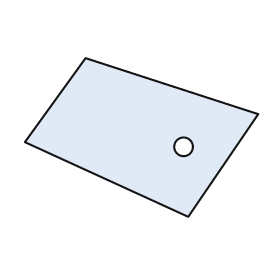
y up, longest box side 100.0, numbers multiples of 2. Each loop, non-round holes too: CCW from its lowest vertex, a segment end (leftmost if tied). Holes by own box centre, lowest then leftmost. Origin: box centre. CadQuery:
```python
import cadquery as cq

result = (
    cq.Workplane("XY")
    .moveTo(20.0, -34.0)
    .lineTo(50.0, 10.0)
    .lineTo(-24.0, 34.0)
    .lineTo(-50.0, -2.0)
    .close()
    .moveTo(18.0, -4.0)
    .circle(4.0)
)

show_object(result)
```